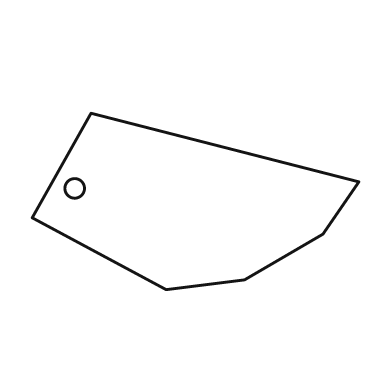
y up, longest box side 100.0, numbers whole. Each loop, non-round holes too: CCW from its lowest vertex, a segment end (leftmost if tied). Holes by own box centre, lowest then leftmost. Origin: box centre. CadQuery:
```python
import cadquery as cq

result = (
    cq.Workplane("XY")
    .moveTo(-9.0, -27.0)
    .lineTo(15.0, -24.0)
    .lineTo(39.0, -10.0)
    .lineTo(50.0, 6.0)
    .lineTo(-32.0, 27.0)
    .lineTo(-50.0, -5.0)
    .close()
    .moveTo(-37.0, 4.0)
    .circle(3.0)
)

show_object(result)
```